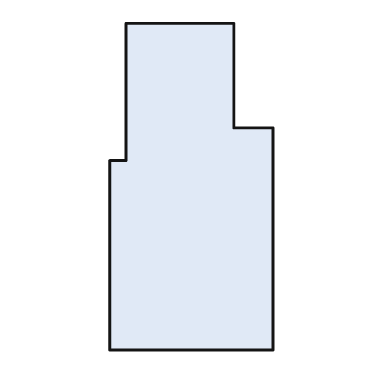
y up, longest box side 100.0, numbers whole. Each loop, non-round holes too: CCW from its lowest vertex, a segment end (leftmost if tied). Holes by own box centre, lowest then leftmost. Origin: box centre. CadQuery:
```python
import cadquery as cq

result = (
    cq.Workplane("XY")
    .moveTo(-25.0, -50.0)
    .lineTo(25.0, -50.0)
    .lineTo(25.0, 18.0)
    .lineTo(13.0, 18.0)
    .lineTo(13.0, 50.0)
    .lineTo(-20.0, 50.0)
    .lineTo(-20.0, 8.0)
    .lineTo(-25.0, 8.0)
    .close()
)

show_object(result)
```